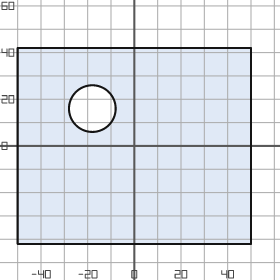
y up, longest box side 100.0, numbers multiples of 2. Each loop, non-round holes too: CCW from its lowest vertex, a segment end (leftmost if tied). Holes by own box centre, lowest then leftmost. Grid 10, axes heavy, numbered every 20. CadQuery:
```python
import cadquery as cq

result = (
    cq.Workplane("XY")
    .moveTo(-50.0, -42.0)
    .lineTo(50.0, -42.0)
    .lineTo(50.0, 42.0)
    .lineTo(-50.0, 42.0)
    .close()
    .moveTo(-18.0, 16.0)
    .circle(10.0)
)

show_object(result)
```